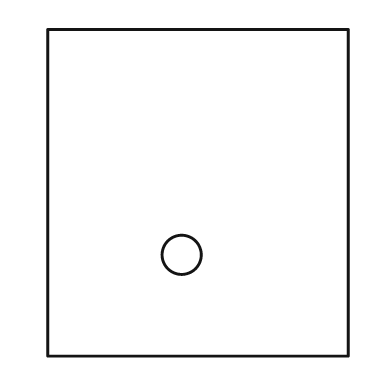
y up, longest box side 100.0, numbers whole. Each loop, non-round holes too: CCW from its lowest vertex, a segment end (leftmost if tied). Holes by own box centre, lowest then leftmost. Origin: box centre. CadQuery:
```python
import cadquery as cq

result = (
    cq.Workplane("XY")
    .moveTo(-46.0, -50.0)
    .lineTo(46.0, -50.0)
    .lineTo(46.0, 50.0)
    .lineTo(-46.0, 50.0)
    .close()
    .moveTo(-5.0, -19.0)
    .circle(6.0)
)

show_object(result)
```